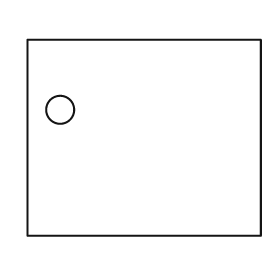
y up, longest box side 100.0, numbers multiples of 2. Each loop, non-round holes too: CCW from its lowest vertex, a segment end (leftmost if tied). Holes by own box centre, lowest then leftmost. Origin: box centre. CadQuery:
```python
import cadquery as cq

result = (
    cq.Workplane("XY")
    .moveTo(-50.0, -42.0)
    .lineTo(50.0, -42.0)
    .lineTo(50.0, 42.0)
    .lineTo(-50.0, 42.0)
    .close()
    .moveTo(-36.0, 12.0)
    .circle(6.0)
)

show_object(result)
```